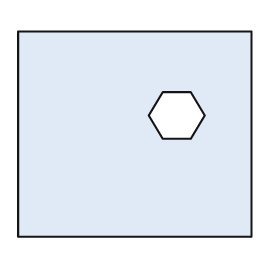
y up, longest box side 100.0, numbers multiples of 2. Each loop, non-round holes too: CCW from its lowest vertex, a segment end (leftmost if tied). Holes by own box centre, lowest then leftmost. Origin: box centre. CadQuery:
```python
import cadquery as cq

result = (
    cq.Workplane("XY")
    .moveTo(-50.0, -44.0)
    .lineTo(50.0, -44.0)
    .lineTo(50.0, 44.0)
    .lineTo(-50.0, 44.0)
    .close()
    .moveTo(12.0, -2.0)
    .lineTo(24.0, -2.0)
    .lineTo(30.0, 8.0)
    .lineTo(24.0, 18.0)
    .lineTo(12.0, 18.0)
    .lineTo(6.0, 8.0)
    .close()
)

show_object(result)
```